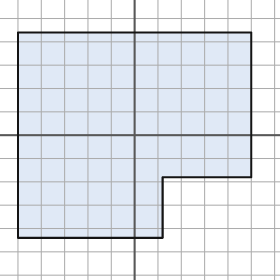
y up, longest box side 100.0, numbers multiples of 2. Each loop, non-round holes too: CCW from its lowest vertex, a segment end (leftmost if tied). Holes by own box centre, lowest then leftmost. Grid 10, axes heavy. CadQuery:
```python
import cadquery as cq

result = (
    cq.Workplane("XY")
    .moveTo(-50.0, -44.0)
    .lineTo(12.0, -44.0)
    .lineTo(12.0, -18.0)
    .lineTo(50.0, -18.0)
    .lineTo(50.0, 44.0)
    .lineTo(-50.0, 44.0)
    .close()
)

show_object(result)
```